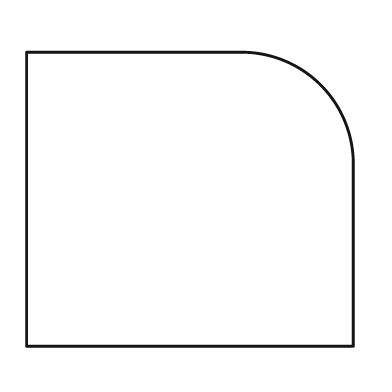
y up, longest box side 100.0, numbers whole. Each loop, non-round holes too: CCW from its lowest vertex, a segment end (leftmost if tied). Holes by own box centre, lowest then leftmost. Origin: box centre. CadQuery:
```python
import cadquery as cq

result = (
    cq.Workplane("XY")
    .moveTo(-50.0, -45.0)
    .lineTo(50.0, -45.0)
    .lineTo(50.0, 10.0)
    .threePointArc((40.0, 35.0), (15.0, 45.0))
    .lineTo(-50.0, 45.0)
    .close()
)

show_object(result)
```